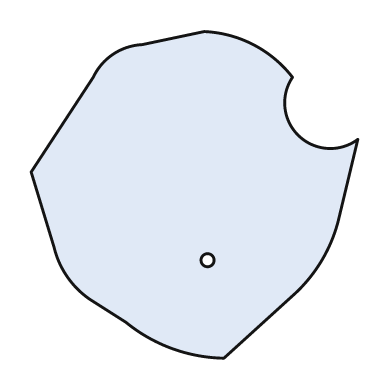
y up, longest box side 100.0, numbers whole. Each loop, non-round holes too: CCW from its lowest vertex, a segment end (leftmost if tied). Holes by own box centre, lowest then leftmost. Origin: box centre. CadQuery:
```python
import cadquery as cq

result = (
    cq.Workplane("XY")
    .moveTo(9.0, -50.0)
    .lineTo(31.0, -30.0)
    .threePointArc((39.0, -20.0), (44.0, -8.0))
    .lineTo(50.0, 17.0)
    .threePointArc((32.0, 18.0), (30.0, 36.0))
    .threePointArc((18.0, 46.0), (3.0, 50.0))
    .lineTo(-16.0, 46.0)
    .threePointArc((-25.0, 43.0), (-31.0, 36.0))
    .lineTo(-50.0, 7.0)
    .lineTo(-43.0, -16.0)
    .threePointArc((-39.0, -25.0), (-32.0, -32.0))
    .lineTo(-21.0, -39.0)
    .threePointArc((-7.0, -47.0), (9.0, -50.0))
    .close()
    .moveTo(4.0, -20.0)
    .circle(2.0)
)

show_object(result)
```